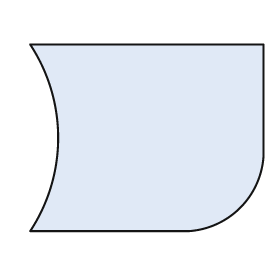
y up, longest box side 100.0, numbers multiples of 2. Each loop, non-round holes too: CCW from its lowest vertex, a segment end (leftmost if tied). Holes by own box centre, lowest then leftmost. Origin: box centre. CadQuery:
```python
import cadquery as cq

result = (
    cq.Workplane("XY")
    .moveTo(-50.0, -40.0)
    .lineTo(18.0, -40.0)
    .threePointArc((40.0, -30.0), (50.0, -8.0))
    .lineTo(50.0, 40.0)
    .lineTo(-50.0, 40.0)
    .threePointArc((-38.0, 0.0), (-50.0, -40.0))
    .close()
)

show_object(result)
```